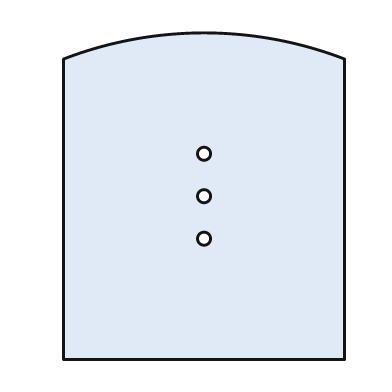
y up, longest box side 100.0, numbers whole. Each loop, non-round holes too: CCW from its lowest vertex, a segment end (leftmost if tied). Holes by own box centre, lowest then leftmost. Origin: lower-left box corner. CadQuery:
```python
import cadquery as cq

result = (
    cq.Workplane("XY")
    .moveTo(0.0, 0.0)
    .lineTo(86.0, 0.0)
    .lineTo(86.0, 92.0)
    .threePointArc((43.0, 100.0), (0.0, 92.0))
    .close()
    .moveTo(43.0, 37.0)
    .circle(2.0)
    .moveTo(43.0, 50.0)
    .circle(2.0)
    .moveTo(43.0, 63.0)
    .circle(2.0)
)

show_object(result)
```